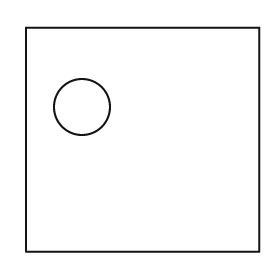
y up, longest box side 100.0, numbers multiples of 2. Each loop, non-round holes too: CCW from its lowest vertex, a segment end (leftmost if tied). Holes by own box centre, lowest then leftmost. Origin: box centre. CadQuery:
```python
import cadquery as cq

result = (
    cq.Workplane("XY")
    .moveTo(-50.0, -48.0)
    .lineTo(50.0, -48.0)
    .lineTo(50.0, 48.0)
    .lineTo(-50.0, 48.0)
    .close()
    .moveTo(-26.0, 14.0)
    .circle(12.0)
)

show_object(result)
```